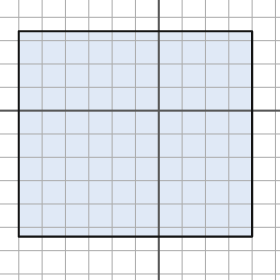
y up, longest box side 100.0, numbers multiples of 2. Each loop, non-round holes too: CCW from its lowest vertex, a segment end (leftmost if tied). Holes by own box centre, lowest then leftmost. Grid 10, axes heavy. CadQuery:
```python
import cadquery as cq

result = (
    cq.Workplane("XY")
    .moveTo(-60.0, -54.0)
    .lineTo(40.0, -54.0)
    .lineTo(40.0, 34.0)
    .lineTo(-60.0, 34.0)
    .close()
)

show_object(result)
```